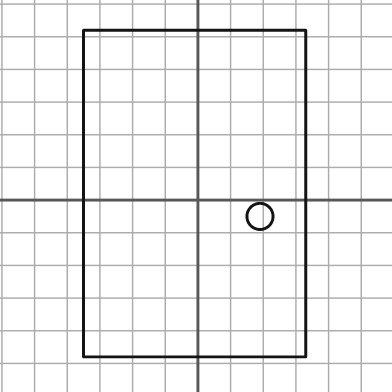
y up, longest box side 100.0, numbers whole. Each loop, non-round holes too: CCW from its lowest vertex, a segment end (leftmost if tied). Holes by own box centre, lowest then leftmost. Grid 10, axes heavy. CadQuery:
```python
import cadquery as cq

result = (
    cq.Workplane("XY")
    .moveTo(-35.0, -48.0)
    .lineTo(33.0, -48.0)
    .lineTo(33.0, 52.0)
    .lineTo(-35.0, 52.0)
    .close()
    .moveTo(19.0, -5.0)
    .circle(4.0)
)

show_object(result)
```